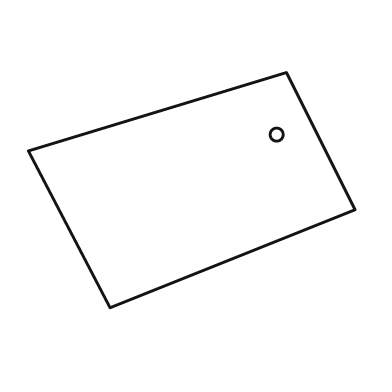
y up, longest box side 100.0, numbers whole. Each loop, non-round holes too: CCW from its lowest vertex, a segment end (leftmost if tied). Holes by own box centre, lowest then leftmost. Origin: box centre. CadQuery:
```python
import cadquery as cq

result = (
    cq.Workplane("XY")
    .moveTo(-25.0, -36.0)
    .lineTo(50.0, -6.0)
    .lineTo(29.0, 36.0)
    .lineTo(-50.0, 12.0)
    .close()
    .moveTo(26.0, 17.0)
    .circle(2.0)
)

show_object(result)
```